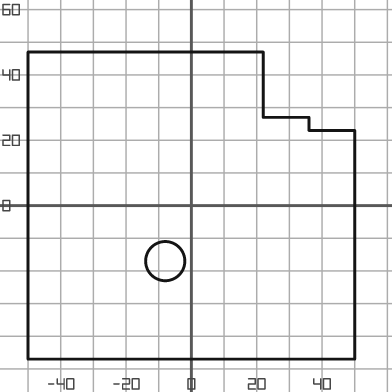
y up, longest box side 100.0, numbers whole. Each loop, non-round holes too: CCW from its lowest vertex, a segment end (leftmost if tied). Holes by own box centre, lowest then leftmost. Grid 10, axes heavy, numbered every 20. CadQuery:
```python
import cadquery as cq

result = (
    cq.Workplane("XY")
    .moveTo(-50.0, -47.0)
    .lineTo(50.0, -47.0)
    .lineTo(50.0, 23.0)
    .lineTo(36.0, 23.0)
    .lineTo(36.0, 27.0)
    .lineTo(22.0, 27.0)
    .lineTo(22.0, 47.0)
    .lineTo(-50.0, 47.0)
    .close()
    .moveTo(-8.0, -17.0)
    .circle(6.0)
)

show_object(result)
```